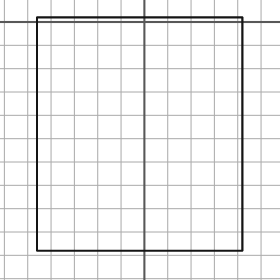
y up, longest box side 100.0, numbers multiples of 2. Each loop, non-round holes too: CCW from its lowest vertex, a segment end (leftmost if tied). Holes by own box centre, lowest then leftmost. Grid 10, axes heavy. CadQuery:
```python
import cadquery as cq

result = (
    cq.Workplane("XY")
    .moveTo(-46.0, -98.0)
    .lineTo(42.0, -98.0)
    .lineTo(42.0, 2.0)
    .lineTo(-46.0, 2.0)
    .close()
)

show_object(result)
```